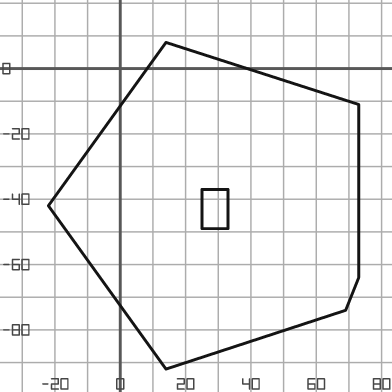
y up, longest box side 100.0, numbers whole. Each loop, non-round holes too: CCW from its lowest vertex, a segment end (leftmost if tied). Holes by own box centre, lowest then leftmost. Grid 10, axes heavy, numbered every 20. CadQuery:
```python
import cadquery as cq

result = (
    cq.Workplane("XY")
    .moveTo(14.0, -92.0)
    .lineTo(69.0, -74.0)
    .lineTo(73.0, -64.0)
    .lineTo(73.0, -11.0)
    .lineTo(14.0, 8.0)
    .lineTo(-22.0, -42.0)
    .close()
    .moveTo(25.0, -49.0)
    .lineTo(33.0, -49.0)
    .lineTo(33.0, -37.0)
    .lineTo(25.0, -37.0)
    .close()
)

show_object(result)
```